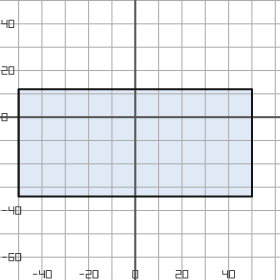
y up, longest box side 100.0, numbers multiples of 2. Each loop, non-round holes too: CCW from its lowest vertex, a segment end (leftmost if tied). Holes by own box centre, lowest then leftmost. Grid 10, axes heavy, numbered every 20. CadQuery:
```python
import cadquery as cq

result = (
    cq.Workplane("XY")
    .moveTo(-50.0, -34.0)
    .lineTo(50.0, -34.0)
    .lineTo(50.0, 12.0)
    .lineTo(-50.0, 12.0)
    .close()
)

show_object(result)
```